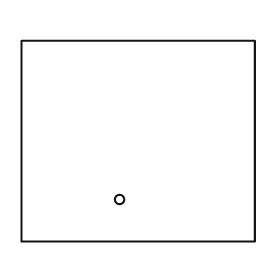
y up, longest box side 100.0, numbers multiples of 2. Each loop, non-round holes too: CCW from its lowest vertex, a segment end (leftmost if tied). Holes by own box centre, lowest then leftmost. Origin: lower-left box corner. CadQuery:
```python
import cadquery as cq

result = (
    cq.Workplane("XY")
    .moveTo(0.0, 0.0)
    .lineTo(100.0, 0.0)
    .lineTo(100.0, 86.0)
    .lineTo(0.0, 86.0)
    .close()
    .moveTo(42.0, 18.0)
    .circle(2.0)
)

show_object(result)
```